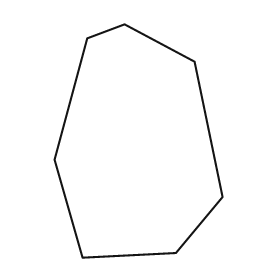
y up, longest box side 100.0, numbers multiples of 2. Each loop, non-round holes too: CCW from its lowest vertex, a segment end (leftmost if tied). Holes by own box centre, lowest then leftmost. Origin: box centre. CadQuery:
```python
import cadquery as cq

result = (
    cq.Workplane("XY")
    .moveTo(-24.0, -50.0)
    .lineTo(16.0, -48.0)
    .lineTo(36.0, -24.0)
    .lineTo(24.0, 34.0)
    .lineTo(-6.0, 50.0)
    .lineTo(-22.0, 44.0)
    .lineTo(-36.0, -8.0)
    .close()
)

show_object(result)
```